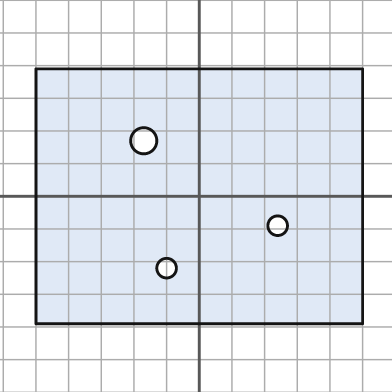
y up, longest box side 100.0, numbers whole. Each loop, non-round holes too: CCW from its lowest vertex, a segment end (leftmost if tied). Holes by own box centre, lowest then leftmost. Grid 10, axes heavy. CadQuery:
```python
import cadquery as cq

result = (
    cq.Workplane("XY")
    .moveTo(-50.0, -39.0)
    .lineTo(50.0, -39.0)
    .lineTo(50.0, 39.0)
    .lineTo(-50.0, 39.0)
    .close()
    .moveTo(-10.0, -22.0)
    .circle(3.0)
    .moveTo(24.0, -9.0)
    .circle(3.0)
    .moveTo(-17.0, 17.0)
    .circle(4.0)
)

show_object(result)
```